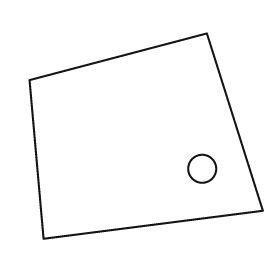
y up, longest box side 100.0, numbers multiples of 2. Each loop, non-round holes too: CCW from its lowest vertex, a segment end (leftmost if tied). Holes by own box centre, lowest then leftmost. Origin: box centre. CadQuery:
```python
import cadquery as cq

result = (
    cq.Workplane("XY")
    .moveTo(-44.0, -44.0)
    .lineTo(50.0, -32.0)
    .lineTo(26.0, 44.0)
    .lineTo(-50.0, 24.0)
    .close()
    .moveTo(24.0, -14.0)
    .circle(6.0)
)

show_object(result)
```